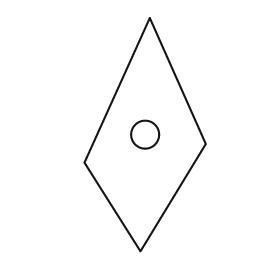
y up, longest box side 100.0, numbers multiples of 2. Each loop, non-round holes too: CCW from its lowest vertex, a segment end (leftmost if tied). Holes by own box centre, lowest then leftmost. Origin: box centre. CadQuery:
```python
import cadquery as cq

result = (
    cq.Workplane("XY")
    .moveTo(-2.0, -50.0)
    .lineTo(26.0, -4.0)
    .lineTo(2.0, 50.0)
    .lineTo(-26.0, -12.0)
    .close()
    .moveTo(0.0, 0.0)
    .circle(6.0)
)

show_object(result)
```